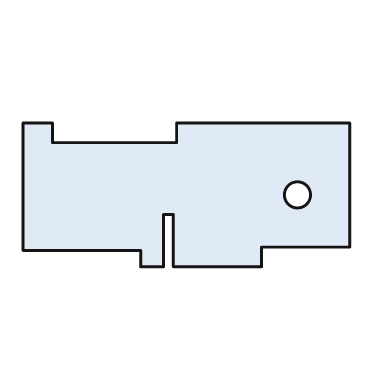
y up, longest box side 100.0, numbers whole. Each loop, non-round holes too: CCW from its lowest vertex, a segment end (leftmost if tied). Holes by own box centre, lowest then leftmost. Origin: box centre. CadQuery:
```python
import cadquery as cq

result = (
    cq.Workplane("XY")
    .moveTo(-14.0, -22.0)
    .lineTo(-7.0, -22.0)
    .lineTo(-7.0, -6.0)
    .lineTo(-4.0, -6.0)
    .lineTo(-4.0, -22.0)
    .lineTo(23.0, -22.0)
    .lineTo(23.0, -16.0)
    .lineTo(50.0, -16.0)
    .lineTo(50.0, 22.0)
    .lineTo(-3.0, 22.0)
    .lineTo(-3.0, 16.0)
    .lineTo(-41.0, 16.0)
    .lineTo(-41.0, 22.0)
    .lineTo(-50.0, 22.0)
    .lineTo(-50.0, -17.0)
    .lineTo(-14.0, -17.0)
    .close()
    .moveTo(34.0, 0.0)
    .circle(4.0)
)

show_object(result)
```